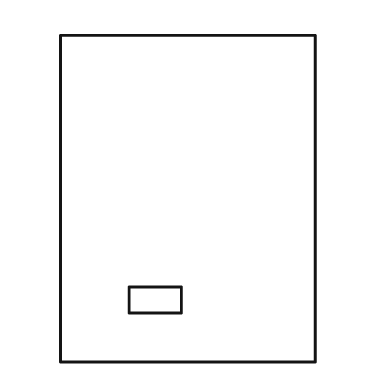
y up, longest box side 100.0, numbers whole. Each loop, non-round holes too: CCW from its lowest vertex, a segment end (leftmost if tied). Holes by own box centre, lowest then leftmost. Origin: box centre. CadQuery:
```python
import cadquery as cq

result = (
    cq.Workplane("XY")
    .moveTo(-39.0, -50.0)
    .lineTo(39.0, -50.0)
    .lineTo(39.0, 50.0)
    .lineTo(-39.0, 50.0)
    .close()
    .moveTo(-18.0, -35.0)
    .lineTo(-2.0, -35.0)
    .lineTo(-2.0, -27.0)
    .lineTo(-18.0, -27.0)
    .close()
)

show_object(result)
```